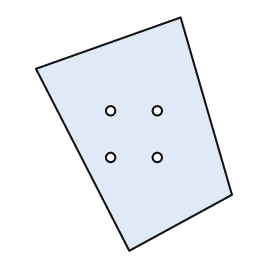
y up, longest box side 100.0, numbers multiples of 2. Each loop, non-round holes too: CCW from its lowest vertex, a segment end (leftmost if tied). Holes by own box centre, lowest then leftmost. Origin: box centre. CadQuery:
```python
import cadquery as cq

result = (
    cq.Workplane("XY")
    .moveTo(-2.0, -50.0)
    .lineTo(42.0, -26.0)
    .lineTo(20.0, 50.0)
    .lineTo(-42.0, 28.0)
    .close()
    .moveTo(-10.0, -10.0)
    .circle(2.0)
    .moveTo(10.0, -10.0)
    .circle(2.0)
    .moveTo(-10.0, 10.0)
    .circle(2.0)
    .moveTo(10.0, 10.0)
    .circle(2.0)
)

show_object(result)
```